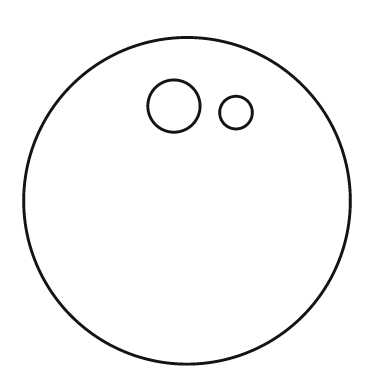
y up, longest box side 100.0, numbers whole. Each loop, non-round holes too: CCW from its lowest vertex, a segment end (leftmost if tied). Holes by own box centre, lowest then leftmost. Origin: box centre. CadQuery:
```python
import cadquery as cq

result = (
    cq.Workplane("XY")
    .moveTo(0.0, 0.0)
    .circle(50.0)
    .moveTo(15.0, 27.0)
    .circle(5.0)
    .moveTo(-4.0, 29.0)
    .circle(8.0)
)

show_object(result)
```